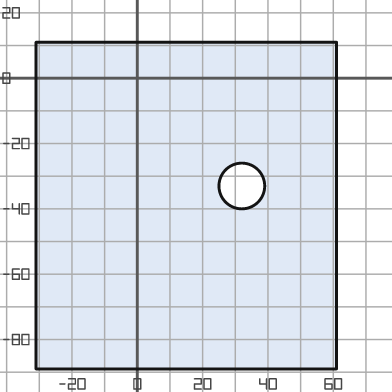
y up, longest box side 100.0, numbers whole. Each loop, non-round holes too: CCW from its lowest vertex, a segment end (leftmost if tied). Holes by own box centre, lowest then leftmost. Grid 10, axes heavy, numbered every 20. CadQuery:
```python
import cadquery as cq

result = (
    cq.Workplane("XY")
    .moveTo(-31.0, -89.0)
    .lineTo(61.0, -89.0)
    .lineTo(61.0, 11.0)
    .lineTo(-31.0, 11.0)
    .close()
    .moveTo(32.0, -33.0)
    .circle(7.0)
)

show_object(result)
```